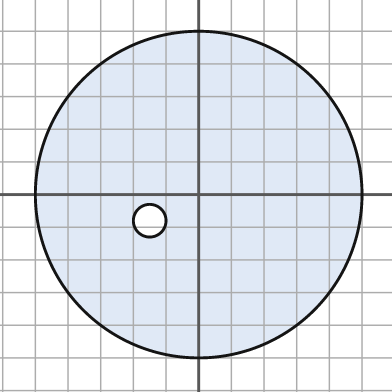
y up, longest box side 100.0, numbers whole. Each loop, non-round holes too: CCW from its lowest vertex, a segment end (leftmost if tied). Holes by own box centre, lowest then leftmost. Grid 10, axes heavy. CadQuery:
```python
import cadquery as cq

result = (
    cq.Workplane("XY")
    .moveTo(0.0, 0.0)
    .circle(50.0)
    .moveTo(-15.0, -8.0)
    .circle(5.0)
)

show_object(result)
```